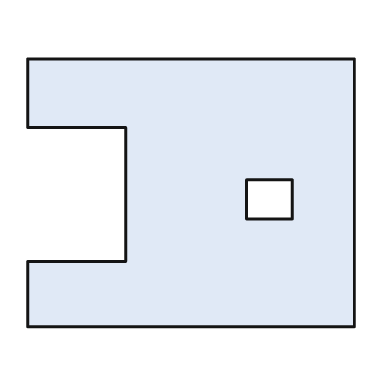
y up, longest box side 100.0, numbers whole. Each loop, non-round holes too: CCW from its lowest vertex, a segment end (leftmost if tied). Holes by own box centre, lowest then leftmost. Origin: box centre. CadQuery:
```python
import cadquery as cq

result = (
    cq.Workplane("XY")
    .moveTo(-50.0, -41.0)
    .lineTo(50.0, -41.0)
    .lineTo(50.0, 41.0)
    .lineTo(-50.0, 41.0)
    .lineTo(-50.0, 20.0)
    .lineTo(-20.0, 20.0)
    .lineTo(-20.0, -21.0)
    .lineTo(-50.0, -21.0)
    .close()
    .moveTo(17.0, -8.0)
    .lineTo(31.0, -8.0)
    .lineTo(31.0, 4.0)
    .lineTo(17.0, 4.0)
    .close()
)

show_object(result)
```